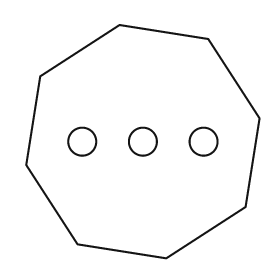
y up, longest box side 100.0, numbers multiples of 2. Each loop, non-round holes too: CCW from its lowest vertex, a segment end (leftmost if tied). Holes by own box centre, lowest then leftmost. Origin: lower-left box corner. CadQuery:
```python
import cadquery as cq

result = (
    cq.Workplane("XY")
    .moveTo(60.0, 0.0)
    .lineTo(94.0, 22.0)
    .lineTo(100.0, 60.0)
    .lineTo(78.0, 94.0)
    .lineTo(40.0, 100.0)
    .lineTo(6.0, 78.0)
    .lineTo(0.0, 40.0)
    .lineTo(22.0, 6.0)
    .close()
    .moveTo(24.0, 50.0)
    .circle(6.0)
    .moveTo(50.0, 50.0)
    .circle(6.0)
    .moveTo(76.0, 50.0)
    .circle(6.0)
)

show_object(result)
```